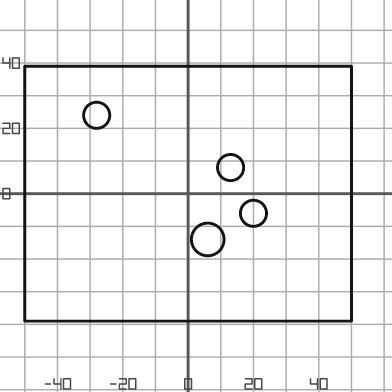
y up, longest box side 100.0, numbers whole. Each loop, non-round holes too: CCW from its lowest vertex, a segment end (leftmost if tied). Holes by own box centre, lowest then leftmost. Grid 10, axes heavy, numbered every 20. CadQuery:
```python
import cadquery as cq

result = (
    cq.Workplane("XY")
    .moveTo(-50.0, -39.0)
    .lineTo(50.0, -39.0)
    .lineTo(50.0, 39.0)
    .lineTo(-50.0, 39.0)
    .close()
    .moveTo(6.0, -14.0)
    .circle(5.0)
    .moveTo(20.0, -6.0)
    .circle(4.0)
    .moveTo(13.0, 8.0)
    .circle(4.0)
    .moveTo(-28.0, 24.0)
    .circle(4.0)
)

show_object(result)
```